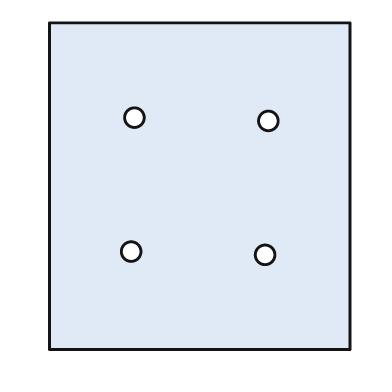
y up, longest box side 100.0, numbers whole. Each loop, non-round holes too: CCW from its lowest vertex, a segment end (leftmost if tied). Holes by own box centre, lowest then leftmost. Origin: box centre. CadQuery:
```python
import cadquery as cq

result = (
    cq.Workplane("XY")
    .moveTo(-46.0, -50.0)
    .lineTo(46.0, -50.0)
    .lineTo(46.0, 50.0)
    .lineTo(-46.0, 50.0)
    .close()
    .moveTo(20.0, -21.0)
    .circle(3.0)
    .moveTo(-21.0, -20.0)
    .circle(3.0)
    .moveTo(21.0, 20.0)
    .circle(3.0)
    .moveTo(-20.0, 21.0)
    .circle(3.0)
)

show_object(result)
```